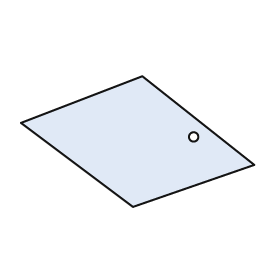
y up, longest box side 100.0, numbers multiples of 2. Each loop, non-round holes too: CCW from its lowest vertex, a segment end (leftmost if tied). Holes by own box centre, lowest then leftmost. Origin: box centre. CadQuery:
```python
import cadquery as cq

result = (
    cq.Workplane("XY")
    .moveTo(-2.0, -28.0)
    .lineTo(50.0, -10.0)
    .lineTo(2.0, 28.0)
    .lineTo(-50.0, 8.0)
    .close()
    .moveTo(24.0, 2.0)
    .circle(2.0)
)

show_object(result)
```